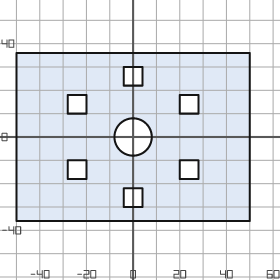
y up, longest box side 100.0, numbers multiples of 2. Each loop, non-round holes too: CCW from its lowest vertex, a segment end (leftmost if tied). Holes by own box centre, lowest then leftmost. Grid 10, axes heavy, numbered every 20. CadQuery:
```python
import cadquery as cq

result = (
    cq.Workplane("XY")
    .moveTo(-50.0, -36.0)
    .lineTo(50.0, -36.0)
    .lineTo(50.0, 36.0)
    .lineTo(-50.0, 36.0)
    .close()
    .moveTo(-4.0, -30.0)
    .lineTo(4.0, -30.0)
    .lineTo(4.0, -22.0)
    .lineTo(-4.0, -22.0)
    .close()
    .moveTo(-28.0, -18.0)
    .lineTo(-20.0, -18.0)
    .lineTo(-20.0, -10.0)
    .lineTo(-28.0, -10.0)
    .close()
    .moveTo(20.0, -18.0)
    .lineTo(28.0, -18.0)
    .lineTo(28.0, -10.0)
    .lineTo(20.0, -10.0)
    .close()
    .moveTo(0.0, 0.0)
    .circle(8.0)
    .moveTo(-28.0, 10.0)
    .lineTo(-20.0, 10.0)
    .lineTo(-20.0, 18.0)
    .lineTo(-28.0, 18.0)
    .close()
    .moveTo(20.0, 10.0)
    .lineTo(28.0, 10.0)
    .lineTo(28.0, 18.0)
    .lineTo(20.0, 18.0)
    .close()
    .moveTo(-4.0, 22.0)
    .lineTo(4.0, 22.0)
    .lineTo(4.0, 30.0)
    .lineTo(-4.0, 30.0)
    .close()
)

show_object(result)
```